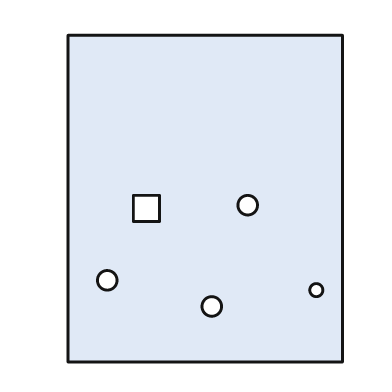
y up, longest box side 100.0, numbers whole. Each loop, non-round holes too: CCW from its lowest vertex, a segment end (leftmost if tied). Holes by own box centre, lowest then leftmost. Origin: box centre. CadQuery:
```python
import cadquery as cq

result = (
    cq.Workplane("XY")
    .moveTo(-42.0, -50.0)
    .lineTo(42.0, -50.0)
    .lineTo(42.0, 50.0)
    .lineTo(-42.0, 50.0)
    .close()
    .moveTo(2.0, -33.0)
    .circle(3.0)
    .moveTo(34.0, -28.0)
    .circle(2.0)
    .moveTo(-30.0, -25.0)
    .circle(3.0)
    .moveTo(-22.0, -7.0)
    .lineTo(-14.0, -7.0)
    .lineTo(-14.0, 1.0)
    .lineTo(-22.0, 1.0)
    .close()
    .moveTo(13.0, -2.0)
    .circle(3.0)
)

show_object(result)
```